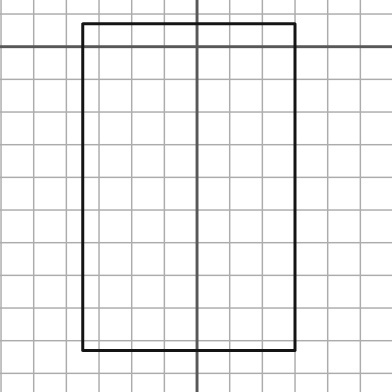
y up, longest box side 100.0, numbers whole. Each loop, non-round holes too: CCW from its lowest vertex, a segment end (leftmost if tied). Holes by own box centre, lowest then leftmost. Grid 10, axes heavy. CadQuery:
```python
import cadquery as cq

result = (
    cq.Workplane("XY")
    .moveTo(-35.0, -93.0)
    .lineTo(30.0, -93.0)
    .lineTo(30.0, 7.0)
    .lineTo(-35.0, 7.0)
    .close()
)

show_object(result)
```